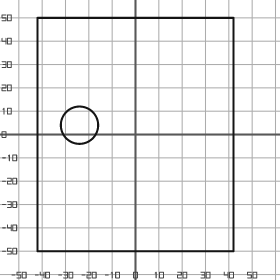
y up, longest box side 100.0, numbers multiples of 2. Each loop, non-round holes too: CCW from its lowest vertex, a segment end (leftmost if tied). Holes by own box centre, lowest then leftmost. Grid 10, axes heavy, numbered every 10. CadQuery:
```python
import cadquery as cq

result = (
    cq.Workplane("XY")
    .moveTo(-42.0, -50.0)
    .lineTo(42.0, -50.0)
    .lineTo(42.0, 50.0)
    .lineTo(-42.0, 50.0)
    .close()
    .moveTo(-24.0, 4.0)
    .circle(8.0)
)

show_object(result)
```